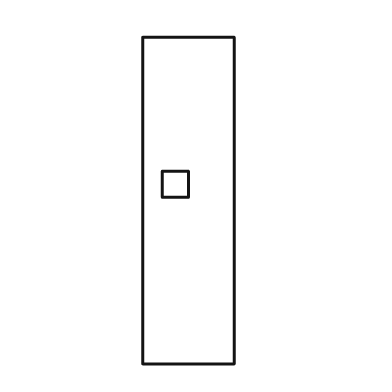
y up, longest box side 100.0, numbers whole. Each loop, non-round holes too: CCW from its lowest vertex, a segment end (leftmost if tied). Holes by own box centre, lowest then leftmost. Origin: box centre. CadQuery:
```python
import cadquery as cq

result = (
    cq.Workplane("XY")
    .moveTo(-14.0, -50.0)
    .lineTo(14.0, -50.0)
    .lineTo(14.0, 50.0)
    .lineTo(-14.0, 50.0)
    .close()
    .moveTo(-8.0, 1.0)
    .lineTo(0.0, 1.0)
    .lineTo(0.0, 9.0)
    .lineTo(-8.0, 9.0)
    .close()
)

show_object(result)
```